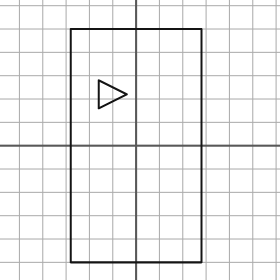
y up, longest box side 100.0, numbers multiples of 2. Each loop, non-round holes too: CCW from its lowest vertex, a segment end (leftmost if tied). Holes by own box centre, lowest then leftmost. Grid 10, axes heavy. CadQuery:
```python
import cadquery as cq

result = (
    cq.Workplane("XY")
    .moveTo(-28.0, -50.0)
    .lineTo(28.0, -50.0)
    .lineTo(28.0, 50.0)
    .lineTo(-28.0, 50.0)
    .close()
    .moveTo(-16.0, 16.0)
    .lineTo(-4.0, 22.0)
    .lineTo(-16.0, 28.0)
    .close()
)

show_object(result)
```